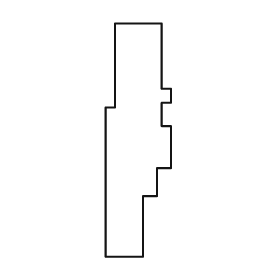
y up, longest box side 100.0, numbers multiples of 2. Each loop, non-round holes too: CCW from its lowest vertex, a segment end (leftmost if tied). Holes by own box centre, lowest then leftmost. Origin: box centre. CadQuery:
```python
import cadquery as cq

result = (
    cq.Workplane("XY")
    .moveTo(-14.0, -50.0)
    .lineTo(2.0, -50.0)
    .lineTo(2.0, -24.0)
    .lineTo(8.0, -24.0)
    .lineTo(8.0, -12.0)
    .lineTo(14.0, -12.0)
    .lineTo(14.0, 6.0)
    .lineTo(10.0, 6.0)
    .lineTo(10.0, 16.0)
    .lineTo(14.0, 16.0)
    .lineTo(14.0, 22.0)
    .lineTo(10.0, 22.0)
    .lineTo(10.0, 50.0)
    .lineTo(-10.0, 50.0)
    .lineTo(-10.0, 14.0)
    .lineTo(-14.0, 14.0)
    .close()
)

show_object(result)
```